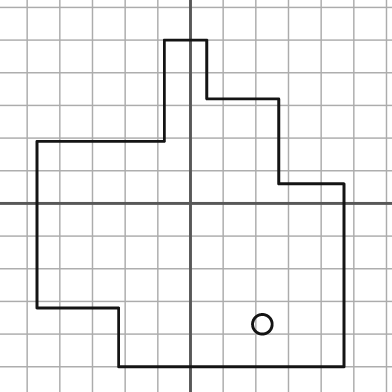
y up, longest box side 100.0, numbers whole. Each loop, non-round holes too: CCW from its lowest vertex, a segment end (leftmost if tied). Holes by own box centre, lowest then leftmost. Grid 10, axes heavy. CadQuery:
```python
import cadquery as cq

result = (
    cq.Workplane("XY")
    .moveTo(-22.0, -50.0)
    .lineTo(47.0, -50.0)
    .lineTo(47.0, 6.0)
    .lineTo(27.0, 6.0)
    .lineTo(27.0, 32.0)
    .lineTo(5.0, 32.0)
    .lineTo(5.0, 50.0)
    .lineTo(-8.0, 50.0)
    .lineTo(-8.0, 19.0)
    .lineTo(-47.0, 19.0)
    .lineTo(-47.0, -32.0)
    .lineTo(-22.0, -32.0)
    .close()
    .moveTo(22.0, -37.0)
    .circle(3.0)
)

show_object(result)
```